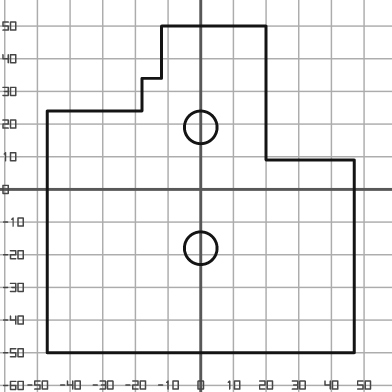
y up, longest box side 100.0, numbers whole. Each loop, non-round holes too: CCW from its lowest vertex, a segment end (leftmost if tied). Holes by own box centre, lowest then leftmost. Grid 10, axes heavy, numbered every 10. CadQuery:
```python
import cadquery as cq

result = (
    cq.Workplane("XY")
    .moveTo(-47.0, -50.0)
    .lineTo(47.0, -50.0)
    .lineTo(47.0, 9.0)
    .lineTo(20.0, 9.0)
    .lineTo(20.0, 50.0)
    .lineTo(-12.0, 50.0)
    .lineTo(-12.0, 34.0)
    .lineTo(-18.0, 34.0)
    .lineTo(-18.0, 24.0)
    .lineTo(-47.0, 24.0)
    .close()
    .moveTo(0.0, -18.0)
    .circle(5.0)
    .moveTo(0.0, 19.0)
    .circle(5.0)
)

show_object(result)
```